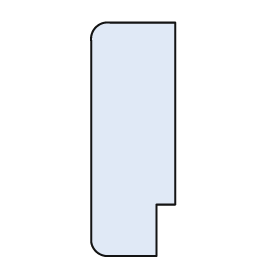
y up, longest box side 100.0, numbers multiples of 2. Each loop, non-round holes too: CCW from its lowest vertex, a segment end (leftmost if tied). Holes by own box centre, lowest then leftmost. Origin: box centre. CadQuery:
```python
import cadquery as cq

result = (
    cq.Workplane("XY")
    .moveTo(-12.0, -50.0)
    .lineTo(10.0, -50.0)
    .lineTo(10.0, -28.0)
    .lineTo(18.0, -28.0)
    .lineTo(18.0, 50.0)
    .lineTo(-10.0, 50.0)
    .threePointArc((-16.0, 48.0), (-18.0, 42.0))
    .lineTo(-18.0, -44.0)
    .threePointArc((-16.0, -48.0), (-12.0, -50.0))
    .close()
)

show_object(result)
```